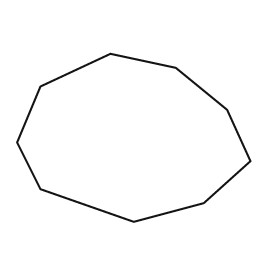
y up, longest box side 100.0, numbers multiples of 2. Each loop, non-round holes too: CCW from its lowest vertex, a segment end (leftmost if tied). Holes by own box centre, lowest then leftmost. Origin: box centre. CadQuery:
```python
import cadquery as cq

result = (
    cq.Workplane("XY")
    .moveTo(0.0, -36.0)
    .lineTo(30.0, -28.0)
    .lineTo(50.0, -10.0)
    .lineTo(40.0, 12.0)
    .lineTo(18.0, 30.0)
    .lineTo(-10.0, 36.0)
    .lineTo(-40.0, 22.0)
    .lineTo(-50.0, -2.0)
    .lineTo(-40.0, -22.0)
    .close()
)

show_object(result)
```